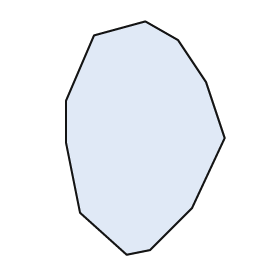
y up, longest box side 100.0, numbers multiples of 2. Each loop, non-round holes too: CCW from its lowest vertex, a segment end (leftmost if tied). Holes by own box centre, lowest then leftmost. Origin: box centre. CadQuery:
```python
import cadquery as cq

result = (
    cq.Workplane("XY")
    .moveTo(-8.0, -50.0)
    .lineTo(2.0, -48.0)
    .lineTo(20.0, -30.0)
    .lineTo(34.0, 0.0)
    .lineTo(26.0, 24.0)
    .lineTo(14.0, 42.0)
    .lineTo(0.0, 50.0)
    .lineTo(-22.0, 44.0)
    .lineTo(-34.0, 16.0)
    .lineTo(-34.0, -2.0)
    .lineTo(-28.0, -32.0)
    .close()
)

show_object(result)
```